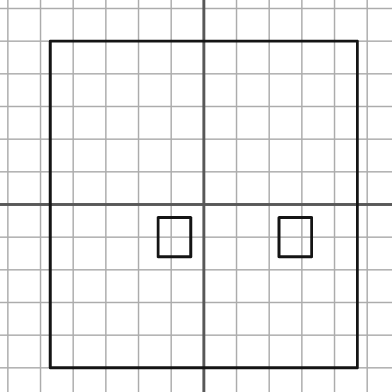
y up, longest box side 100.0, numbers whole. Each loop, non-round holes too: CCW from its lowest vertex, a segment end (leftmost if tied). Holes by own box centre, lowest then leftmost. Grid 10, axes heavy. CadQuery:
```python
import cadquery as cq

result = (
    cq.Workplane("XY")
    .moveTo(-47.0, -50.0)
    .lineTo(47.0, -50.0)
    .lineTo(47.0, 50.0)
    .lineTo(-47.0, 50.0)
    .close()
    .moveTo(-14.0, -16.0)
    .lineTo(-4.0, -16.0)
    .lineTo(-4.0, -4.0)
    .lineTo(-14.0, -4.0)
    .close()
    .moveTo(23.0, -16.0)
    .lineTo(33.0, -16.0)
    .lineTo(33.0, -4.0)
    .lineTo(23.0, -4.0)
    .close()
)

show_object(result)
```